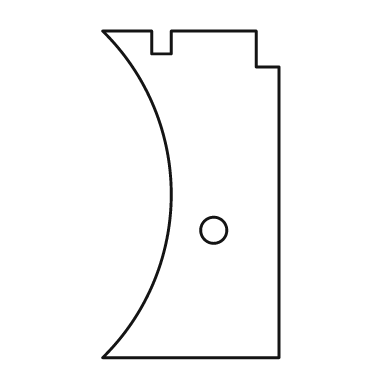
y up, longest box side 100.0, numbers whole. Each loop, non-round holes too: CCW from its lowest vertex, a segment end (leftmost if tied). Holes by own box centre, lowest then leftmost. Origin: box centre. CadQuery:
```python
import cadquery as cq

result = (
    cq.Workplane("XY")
    .moveTo(-27.0, -50.0)
    .lineTo(27.0, -50.0)
    .lineTo(27.0, 39.0)
    .lineTo(20.0, 39.0)
    .lineTo(20.0, 50.0)
    .lineTo(-6.0, 50.0)
    .lineTo(-6.0, 43.0)
    .lineTo(-12.0, 43.0)
    .lineTo(-12.0, 50.0)
    .lineTo(-27.0, 50.0)
    .threePointArc((-6.0, 0.0), (-27.0, -50.0))
    .close()
    .moveTo(7.0, -11.0)
    .circle(4.0)
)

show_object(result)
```